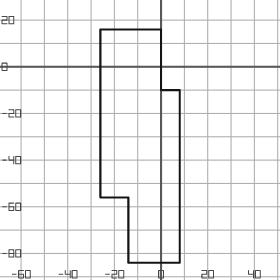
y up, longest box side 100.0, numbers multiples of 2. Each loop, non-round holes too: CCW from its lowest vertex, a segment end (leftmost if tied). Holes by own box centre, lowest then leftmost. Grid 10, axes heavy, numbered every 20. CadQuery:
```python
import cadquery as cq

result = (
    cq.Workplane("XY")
    .moveTo(-14.0, -84.0)
    .lineTo(8.0, -84.0)
    .lineTo(8.0, -10.0)
    .lineTo(0.0, -10.0)
    .lineTo(0.0, 16.0)
    .lineTo(-26.0, 16.0)
    .lineTo(-26.0, -56.0)
    .lineTo(-14.0, -56.0)
    .close()
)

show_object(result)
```